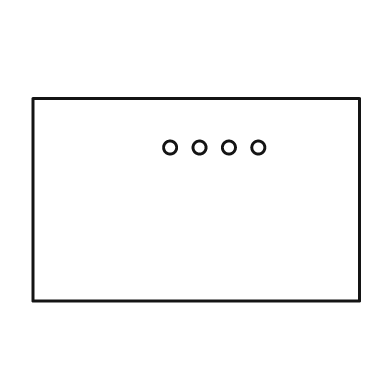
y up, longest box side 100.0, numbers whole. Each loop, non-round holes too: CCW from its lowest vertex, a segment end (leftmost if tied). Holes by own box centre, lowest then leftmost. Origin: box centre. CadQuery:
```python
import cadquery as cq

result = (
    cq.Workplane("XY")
    .moveTo(-50.0, -31.0)
    .lineTo(50.0, -31.0)
    .lineTo(50.0, 31.0)
    .lineTo(-50.0, 31.0)
    .close()
    .moveTo(-8.0, 16.0)
    .circle(2.0)
    .moveTo(1.0, 16.0)
    .circle(2.0)
    .moveTo(10.0, 16.0)
    .circle(2.0)
    .moveTo(19.0, 16.0)
    .circle(2.0)
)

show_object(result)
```